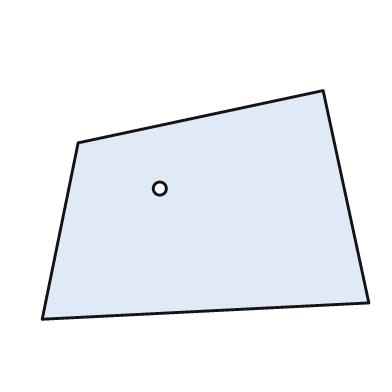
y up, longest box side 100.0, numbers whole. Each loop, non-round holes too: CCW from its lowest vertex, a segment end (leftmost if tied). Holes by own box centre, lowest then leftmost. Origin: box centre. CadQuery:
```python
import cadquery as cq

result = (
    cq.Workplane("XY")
    .moveTo(-50.0, -35.0)
    .lineTo(50.0, -30.0)
    .lineTo(36.0, 35.0)
    .lineTo(-39.0, 19.0)
    .close()
    .moveTo(-14.0, 5.0)
    .circle(2.0)
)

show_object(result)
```